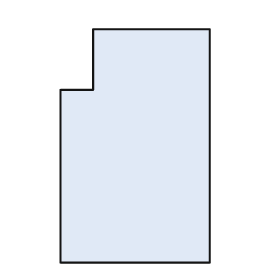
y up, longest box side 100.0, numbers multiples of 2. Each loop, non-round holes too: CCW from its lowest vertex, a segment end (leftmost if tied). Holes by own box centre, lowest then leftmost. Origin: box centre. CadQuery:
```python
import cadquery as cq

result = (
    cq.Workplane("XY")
    .moveTo(-32.0, -50.0)
    .lineTo(32.0, -50.0)
    .lineTo(32.0, 50.0)
    .lineTo(-18.0, 50.0)
    .lineTo(-18.0, 24.0)
    .lineTo(-32.0, 24.0)
    .close()
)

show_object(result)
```